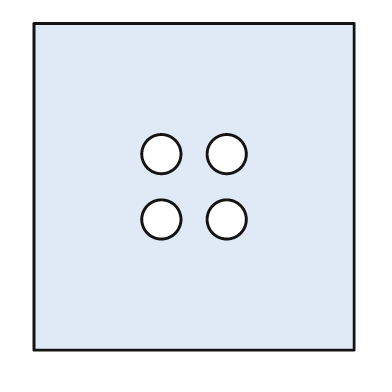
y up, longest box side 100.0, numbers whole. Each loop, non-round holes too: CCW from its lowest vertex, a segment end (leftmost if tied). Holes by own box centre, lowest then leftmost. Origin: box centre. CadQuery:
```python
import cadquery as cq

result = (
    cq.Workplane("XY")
    .moveTo(-49.0, -50.0)
    .lineTo(49.0, -50.0)
    .lineTo(49.0, 50.0)
    .lineTo(-49.0, 50.0)
    .close()
    .moveTo(-10.0, -10.0)
    .circle(6.0)
    .moveTo(10.0, -10.0)
    .circle(6.0)
    .moveTo(-10.0, 10.0)
    .circle(6.0)
    .moveTo(10.0, 10.0)
    .circle(6.0)
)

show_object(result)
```